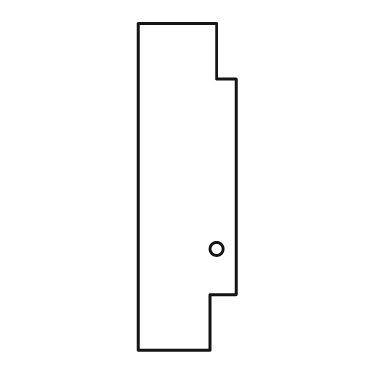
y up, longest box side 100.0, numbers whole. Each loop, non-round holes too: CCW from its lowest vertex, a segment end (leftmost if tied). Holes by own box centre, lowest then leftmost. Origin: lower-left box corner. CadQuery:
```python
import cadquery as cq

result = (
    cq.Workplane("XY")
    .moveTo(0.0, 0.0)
    .lineTo(22.0, 0.0)
    .lineTo(22.0, 17.0)
    .lineTo(30.0, 17.0)
    .lineTo(30.0, 83.0)
    .lineTo(24.0, 83.0)
    .lineTo(24.0, 100.0)
    .lineTo(0.0, 100.0)
    .close()
    .moveTo(24.0, 31.0)
    .circle(2.0)
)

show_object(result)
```